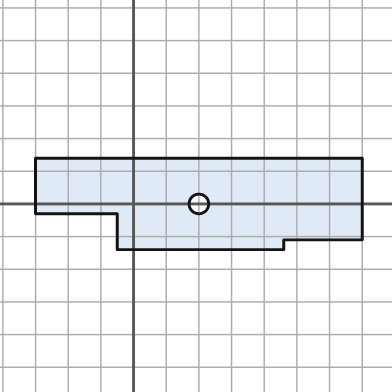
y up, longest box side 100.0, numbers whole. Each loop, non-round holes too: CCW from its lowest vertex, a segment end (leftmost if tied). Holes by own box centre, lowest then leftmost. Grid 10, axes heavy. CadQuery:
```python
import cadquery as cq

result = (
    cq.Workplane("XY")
    .moveTo(-5.0, -14.0)
    .lineTo(46.0, -14.0)
    .lineTo(46.0, -11.0)
    .lineTo(70.0, -11.0)
    .lineTo(70.0, 14.0)
    .lineTo(-30.0, 14.0)
    .lineTo(-30.0, -3.0)
    .lineTo(-5.0, -3.0)
    .close()
    .moveTo(20.0, 0.0)
    .circle(3.0)
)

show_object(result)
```